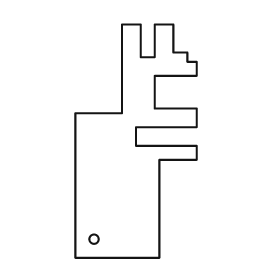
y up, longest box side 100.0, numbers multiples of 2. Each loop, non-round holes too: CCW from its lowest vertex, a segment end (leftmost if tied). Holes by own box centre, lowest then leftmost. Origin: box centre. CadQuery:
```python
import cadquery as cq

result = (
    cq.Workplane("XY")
    .moveTo(-26.0, -50.0)
    .lineTo(10.0, -50.0)
    .lineTo(10.0, -8.0)
    .lineTo(26.0, -8.0)
    .lineTo(26.0, -2.0)
    .lineTo(0.0, -2.0)
    .lineTo(0.0, 6.0)
    .lineTo(26.0, 6.0)
    .lineTo(26.0, 14.0)
    .lineTo(8.0, 14.0)
    .lineTo(8.0, 28.0)
    .lineTo(26.0, 28.0)
    .lineTo(26.0, 34.0)
    .lineTo(22.0, 34.0)
    .lineTo(22.0, 38.0)
    .lineTo(16.0, 38.0)
    .lineTo(16.0, 50.0)
    .lineTo(8.0, 50.0)
    .lineTo(8.0, 36.0)
    .lineTo(2.0, 36.0)
    .lineTo(2.0, 50.0)
    .lineTo(-6.0, 50.0)
    .lineTo(-6.0, 12.0)
    .lineTo(-26.0, 12.0)
    .close()
    .moveTo(-18.0, -42.0)
    .circle(2.0)
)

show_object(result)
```